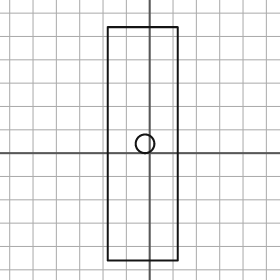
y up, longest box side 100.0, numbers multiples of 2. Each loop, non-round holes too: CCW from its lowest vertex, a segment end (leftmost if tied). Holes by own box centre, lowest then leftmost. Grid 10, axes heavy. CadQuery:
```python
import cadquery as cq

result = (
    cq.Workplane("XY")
    .moveTo(-18.0, -46.0)
    .lineTo(12.0, -46.0)
    .lineTo(12.0, 54.0)
    .lineTo(-18.0, 54.0)
    .close()
    .moveTo(-2.0, 4.0)
    .circle(4.0)
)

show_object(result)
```